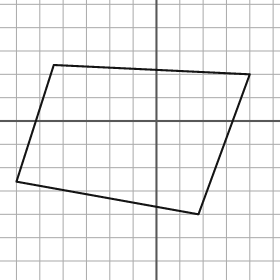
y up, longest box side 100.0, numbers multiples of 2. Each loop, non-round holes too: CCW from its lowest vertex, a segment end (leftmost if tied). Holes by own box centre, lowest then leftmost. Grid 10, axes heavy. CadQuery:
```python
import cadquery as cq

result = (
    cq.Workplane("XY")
    .moveTo(18.0, -40.0)
    .lineTo(40.0, 20.0)
    .lineTo(-44.0, 24.0)
    .lineTo(-60.0, -26.0)
    .close()
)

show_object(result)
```